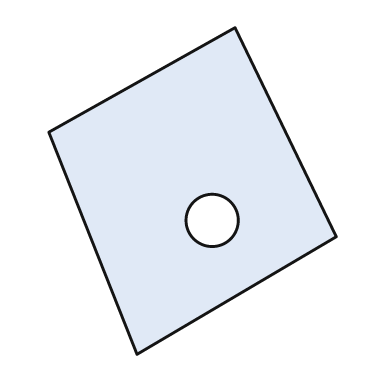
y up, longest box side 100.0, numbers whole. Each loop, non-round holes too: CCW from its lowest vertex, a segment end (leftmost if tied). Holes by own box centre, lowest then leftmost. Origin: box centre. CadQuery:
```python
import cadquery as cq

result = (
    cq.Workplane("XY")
    .moveTo(-17.0, -50.0)
    .lineTo(44.0, -14.0)
    .lineTo(13.0, 50.0)
    .lineTo(-44.0, 18.0)
    .close()
    .moveTo(6.0, -9.0)
    .circle(8.0)
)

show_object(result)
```